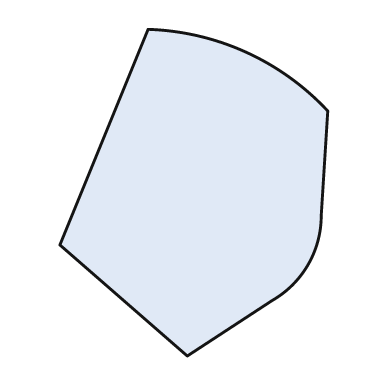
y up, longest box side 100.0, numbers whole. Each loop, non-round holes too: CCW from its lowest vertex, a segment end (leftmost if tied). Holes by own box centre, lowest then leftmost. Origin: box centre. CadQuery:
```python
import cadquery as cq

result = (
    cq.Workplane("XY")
    .moveTo(-2.0, -50.0)
    .lineTo(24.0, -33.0)
    .threePointArc((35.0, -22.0), (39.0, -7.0))
    .lineTo(41.0, 25.0)
    .threePointArc((16.0, 43.0), (-14.0, 50.0))
    .lineTo(-41.0, -16.0)
    .close()
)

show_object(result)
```